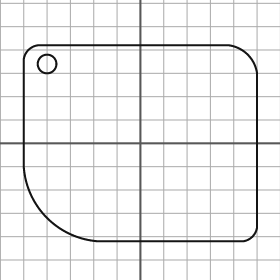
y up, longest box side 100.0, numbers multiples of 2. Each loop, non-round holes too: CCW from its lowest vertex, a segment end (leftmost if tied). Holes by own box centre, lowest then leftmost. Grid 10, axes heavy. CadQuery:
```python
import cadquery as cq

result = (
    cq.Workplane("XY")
    .moveTo(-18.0, -42.0)
    .lineTo(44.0, -42.0)
    .threePointArc((48.0, -40.0), (50.0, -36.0))
    .lineTo(50.0, 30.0)
    .threePointArc((46.0, 38.0), (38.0, 42.0))
    .lineTo(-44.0, 42.0)
    .threePointArc((-48.0, 40.0), (-50.0, 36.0))
    .lineTo(-50.0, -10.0)
    .threePointArc((-40.0, -32.0), (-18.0, -42.0))
    .close()
    .moveTo(-40.0, 34.0)
    .circle(4.0)
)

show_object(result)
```